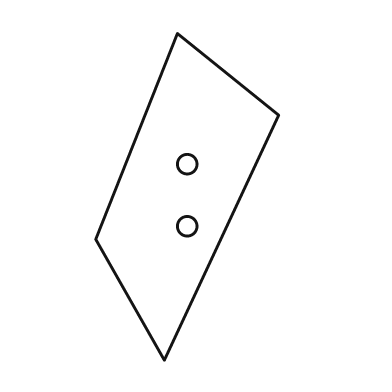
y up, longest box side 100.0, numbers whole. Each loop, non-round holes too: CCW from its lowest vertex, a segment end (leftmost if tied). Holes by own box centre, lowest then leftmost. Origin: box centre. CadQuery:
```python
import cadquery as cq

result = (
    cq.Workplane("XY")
    .moveTo(-7.0, -50.0)
    .lineTo(28.0, 25.0)
    .lineTo(-3.0, 50.0)
    .lineTo(-28.0, -13.0)
    .close()
    .moveTo(0.0, -9.0)
    .circle(3.0)
    .moveTo(0.0, 10.0)
    .circle(3.0)
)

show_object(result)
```